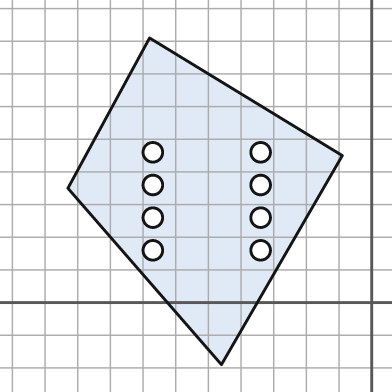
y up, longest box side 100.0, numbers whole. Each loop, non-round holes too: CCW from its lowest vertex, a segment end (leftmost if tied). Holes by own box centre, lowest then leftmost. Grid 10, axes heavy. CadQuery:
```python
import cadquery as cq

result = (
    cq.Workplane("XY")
    .moveTo(-46.0, -19.0)
    .lineTo(-9.0, 45.0)
    .lineTo(-68.0, 81.0)
    .lineTo(-93.0, 35.0)
    .close()
    .moveTo(-67.0, 16.0)
    .circle(3.0)
    .moveTo(-34.0, 16.0)
    .circle(3.0)
    .moveTo(-67.0, 26.0)
    .circle(3.0)
    .moveTo(-34.0, 26.0)
    .circle(3.0)
    .moveTo(-67.0, 36.0)
    .circle(3.0)
    .moveTo(-34.0, 36.0)
    .circle(3.0)
    .moveTo(-67.0, 46.0)
    .circle(3.0)
    .moveTo(-34.0, 46.0)
    .circle(3.0)
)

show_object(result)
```